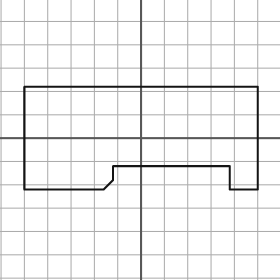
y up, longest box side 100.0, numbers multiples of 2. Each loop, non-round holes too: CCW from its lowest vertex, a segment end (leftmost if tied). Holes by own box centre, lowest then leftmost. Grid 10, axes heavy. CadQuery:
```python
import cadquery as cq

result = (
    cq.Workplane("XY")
    .moveTo(-50.0, -22.0)
    .lineTo(-16.0, -22.0)
    .lineTo(-12.0, -18.0)
    .lineTo(-12.0, -12.0)
    .lineTo(38.0, -12.0)
    .lineTo(38.0, -22.0)
    .lineTo(50.0, -22.0)
    .lineTo(50.0, 22.0)
    .lineTo(-50.0, 22.0)
    .close()
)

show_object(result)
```